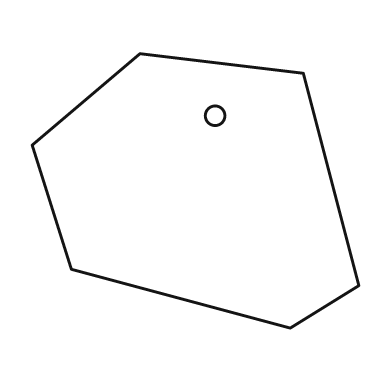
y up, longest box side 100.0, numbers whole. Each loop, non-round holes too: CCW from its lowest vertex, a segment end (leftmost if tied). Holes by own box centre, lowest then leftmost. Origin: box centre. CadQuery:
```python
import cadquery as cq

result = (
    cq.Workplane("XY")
    .moveTo(29.0, -42.0)
    .lineTo(50.0, -29.0)
    .lineTo(33.0, 36.0)
    .lineTo(-17.0, 42.0)
    .lineTo(-50.0, 14.0)
    .lineTo(-38.0, -24.0)
    .close()
    .moveTo(6.0, 23.0)
    .circle(3.0)
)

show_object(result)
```